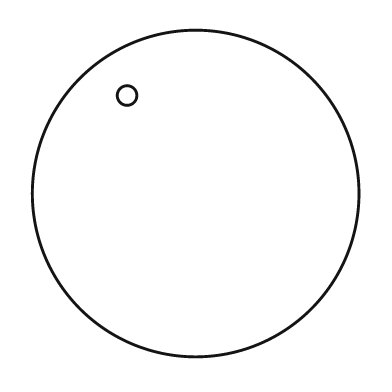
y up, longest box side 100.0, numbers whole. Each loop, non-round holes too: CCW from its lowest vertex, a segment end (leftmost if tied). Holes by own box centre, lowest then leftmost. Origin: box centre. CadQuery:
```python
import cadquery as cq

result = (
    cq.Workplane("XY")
    .moveTo(0.0, 0.0)
    .circle(50.0)
    .moveTo(-21.0, 30.0)
    .circle(3.0)
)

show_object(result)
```